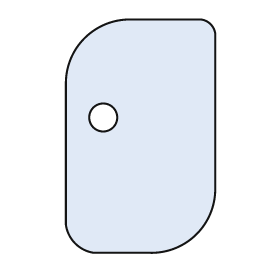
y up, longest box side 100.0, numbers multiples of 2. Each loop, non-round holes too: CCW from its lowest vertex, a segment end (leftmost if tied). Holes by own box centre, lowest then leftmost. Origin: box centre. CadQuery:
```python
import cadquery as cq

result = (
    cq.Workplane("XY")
    .moveTo(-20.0, -50.0)
    .lineTo(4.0, -50.0)
    .threePointArc((24.0, -42.0), (32.0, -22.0))
    .lineTo(32.0, 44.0)
    .threePointArc((30.0, 48.0), (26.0, 50.0))
    .lineTo(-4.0, 50.0)
    .threePointArc((-24.0, 42.0), (-32.0, 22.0))
    .lineTo(-32.0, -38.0)
    .threePointArc((-28.0, -46.0), (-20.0, -50.0))
    .close()
    .moveTo(-16.0, 8.0)
    .circle(6.0)
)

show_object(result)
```